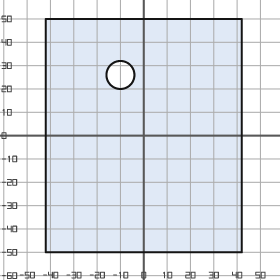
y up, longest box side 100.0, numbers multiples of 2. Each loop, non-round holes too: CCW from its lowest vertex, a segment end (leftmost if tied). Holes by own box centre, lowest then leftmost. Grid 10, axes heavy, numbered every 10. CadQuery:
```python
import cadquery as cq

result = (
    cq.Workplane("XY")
    .moveTo(-42.0, -50.0)
    .lineTo(42.0, -50.0)
    .lineTo(42.0, 50.0)
    .lineTo(-42.0, 50.0)
    .close()
    .moveTo(-10.0, 26.0)
    .circle(6.0)
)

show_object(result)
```